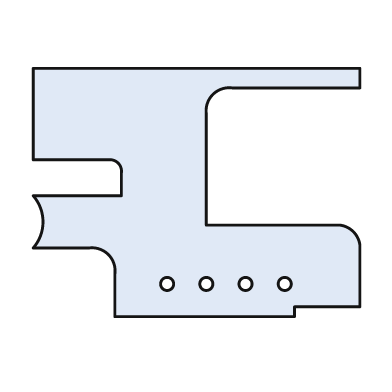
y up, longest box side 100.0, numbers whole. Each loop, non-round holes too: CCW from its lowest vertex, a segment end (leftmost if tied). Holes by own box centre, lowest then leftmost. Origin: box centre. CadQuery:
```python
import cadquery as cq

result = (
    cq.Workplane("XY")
    .moveTo(-25.0, -38.0)
    .lineTo(30.0, -38.0)
    .lineTo(30.0, -35.0)
    .lineTo(50.0, -35.0)
    .lineTo(50.0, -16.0)
    .threePointArc((48.0, -12.0), (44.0, -10.0))
    .lineTo(3.0, -10.0)
    .lineTo(3.0, 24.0)
    .threePointArc((5.0, 30.0), (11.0, 32.0))
    .lineTo(50.0, 32.0)
    .lineTo(50.0, 38.0)
    .lineTo(-50.0, 38.0)
    .lineTo(-50.0, 10.0)
    .lineTo(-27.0, 10.0)
    .threePointArc((-24.0, 9.0), (-23.0, 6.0))
    .lineTo(-23.0, -1.0)
    .lineTo(-50.0, -1.0)
    .threePointArc((-47.0, -9.0), (-50.0, -17.0))
    .lineTo(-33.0, -17.0)
    .threePointArc((-27.0, -19.0), (-25.0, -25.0))
    .close()
    .moveTo(-9.0, -28.0)
    .circle(2.0)
    .moveTo(3.0, -28.0)
    .circle(2.0)
    .moveTo(15.0, -28.0)
    .circle(2.0)
    .moveTo(27.0, -28.0)
    .circle(2.0)
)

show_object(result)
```